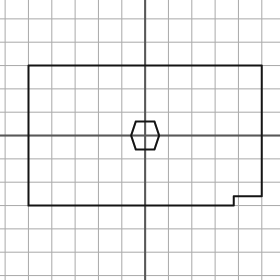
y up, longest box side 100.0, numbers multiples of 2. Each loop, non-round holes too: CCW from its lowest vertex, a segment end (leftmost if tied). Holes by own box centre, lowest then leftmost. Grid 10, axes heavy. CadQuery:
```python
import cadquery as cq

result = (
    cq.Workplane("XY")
    .moveTo(-50.0, -30.0)
    .lineTo(38.0, -30.0)
    .lineTo(38.0, -26.0)
    .lineTo(50.0, -26.0)
    .lineTo(50.0, 30.0)
    .lineTo(-50.0, 30.0)
    .close()
    .moveTo(-4.0, -6.0)
    .lineTo(4.0, -6.0)
    .lineTo(6.0, 0.0)
    .lineTo(4.0, 6.0)
    .lineTo(-4.0, 6.0)
    .lineTo(-6.0, 0.0)
    .close()
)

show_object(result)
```